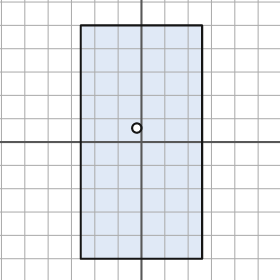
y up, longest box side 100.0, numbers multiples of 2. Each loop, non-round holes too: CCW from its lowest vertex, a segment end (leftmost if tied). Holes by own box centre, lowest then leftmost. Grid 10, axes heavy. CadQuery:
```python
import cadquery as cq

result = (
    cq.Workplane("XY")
    .moveTo(-26.0, -50.0)
    .lineTo(26.0, -50.0)
    .lineTo(26.0, 50.0)
    .lineTo(-26.0, 50.0)
    .close()
    .moveTo(-2.0, 6.0)
    .circle(2.0)
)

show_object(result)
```